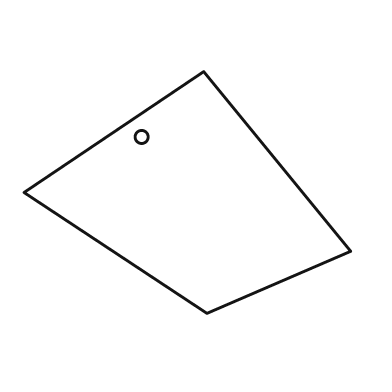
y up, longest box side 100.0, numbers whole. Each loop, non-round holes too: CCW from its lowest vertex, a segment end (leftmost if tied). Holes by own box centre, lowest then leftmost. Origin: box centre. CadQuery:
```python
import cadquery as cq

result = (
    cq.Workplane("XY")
    .moveTo(6.0, -37.0)
    .lineTo(50.0, -18.0)
    .lineTo(5.0, 37.0)
    .lineTo(-50.0, 0.0)
    .close()
    .moveTo(-14.0, 17.0)
    .circle(2.0)
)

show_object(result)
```